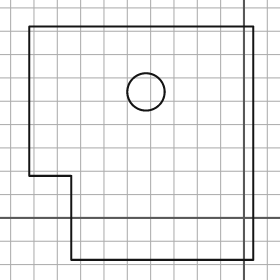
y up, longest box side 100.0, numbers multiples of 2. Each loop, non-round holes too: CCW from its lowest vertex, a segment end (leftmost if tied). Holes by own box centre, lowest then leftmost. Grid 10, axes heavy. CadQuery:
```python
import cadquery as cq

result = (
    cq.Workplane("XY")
    .moveTo(-74.0, -18.0)
    .lineTo(4.0, -18.0)
    .lineTo(4.0, 82.0)
    .lineTo(-92.0, 82.0)
    .lineTo(-92.0, 18.0)
    .lineTo(-74.0, 18.0)
    .close()
    .moveTo(-42.0, 54.0)
    .circle(8.0)
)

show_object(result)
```